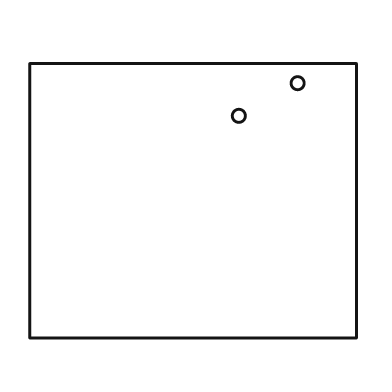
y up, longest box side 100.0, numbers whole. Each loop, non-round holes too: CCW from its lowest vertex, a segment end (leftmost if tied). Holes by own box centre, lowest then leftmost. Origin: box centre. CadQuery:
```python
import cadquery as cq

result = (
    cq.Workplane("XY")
    .moveTo(-50.0, -42.0)
    .lineTo(50.0, -42.0)
    .lineTo(50.0, 42.0)
    .lineTo(-50.0, 42.0)
    .close()
    .moveTo(14.0, 26.0)
    .circle(2.0)
    .moveTo(32.0, 36.0)
    .circle(2.0)
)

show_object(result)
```